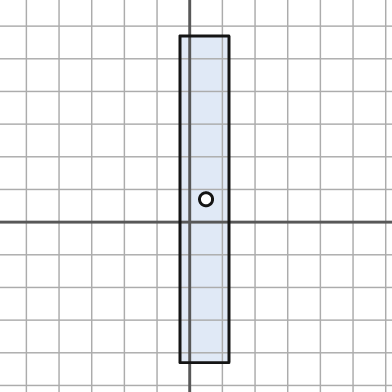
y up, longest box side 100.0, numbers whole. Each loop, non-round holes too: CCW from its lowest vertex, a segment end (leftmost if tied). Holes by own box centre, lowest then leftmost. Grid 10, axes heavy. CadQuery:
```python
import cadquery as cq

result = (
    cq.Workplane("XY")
    .moveTo(-3.0, -43.0)
    .lineTo(12.0, -43.0)
    .lineTo(12.0, 57.0)
    .lineTo(-3.0, 57.0)
    .close()
    .moveTo(5.0, 7.0)
    .circle(2.0)
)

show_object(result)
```